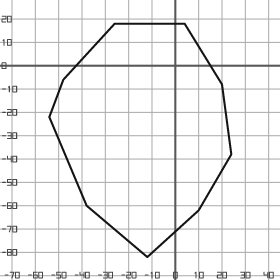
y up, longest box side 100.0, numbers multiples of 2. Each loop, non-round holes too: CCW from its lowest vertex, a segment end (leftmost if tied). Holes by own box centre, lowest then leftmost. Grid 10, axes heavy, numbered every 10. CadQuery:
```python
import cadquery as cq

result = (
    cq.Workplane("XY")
    .moveTo(-12.0, -82.0)
    .lineTo(10.0, -62.0)
    .lineTo(24.0, -38.0)
    .lineTo(20.0, -8.0)
    .lineTo(4.0, 18.0)
    .lineTo(-26.0, 18.0)
    .lineTo(-48.0, -6.0)
    .lineTo(-54.0, -22.0)
    .lineTo(-38.0, -60.0)
    .close()
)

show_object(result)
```